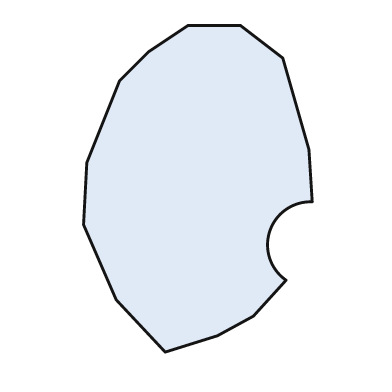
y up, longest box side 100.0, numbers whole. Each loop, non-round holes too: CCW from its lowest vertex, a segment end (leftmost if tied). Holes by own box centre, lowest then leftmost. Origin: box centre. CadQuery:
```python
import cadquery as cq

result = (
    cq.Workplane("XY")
    .moveTo(-10.0, -50.0)
    .lineTo(6.0, -45.0)
    .lineTo(17.0, -39.0)
    .lineTo(27.0, -28.0)
    .threePointArc((22.0, -13.0), (35.0, -4.0))
    .lineTo(34.0, 12.0)
    .lineTo(26.0, 40.0)
    .lineTo(13.0, 50.0)
    .lineTo(-3.0, 50.0)
    .lineTo(-15.0, 42.0)
    .lineTo(-24.0, 33.0)
    .lineTo(-34.0, 8.0)
    .lineTo(-35.0, -11.0)
    .lineTo(-25.0, -34.0)
    .close()
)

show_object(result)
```